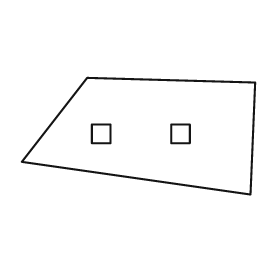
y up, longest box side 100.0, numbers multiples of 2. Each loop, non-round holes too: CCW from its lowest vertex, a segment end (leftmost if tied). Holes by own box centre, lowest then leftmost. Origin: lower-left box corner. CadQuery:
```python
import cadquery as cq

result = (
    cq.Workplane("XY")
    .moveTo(98.0, 0.0)
    .lineTo(100.0, 48.0)
    .lineTo(28.0, 50.0)
    .lineTo(0.0, 14.0)
    .close()
    .moveTo(30.0, 22.0)
    .lineTo(38.0, 22.0)
    .lineTo(38.0, 30.0)
    .lineTo(30.0, 30.0)
    .close()
    .moveTo(64.0, 22.0)
    .lineTo(72.0, 22.0)
    .lineTo(72.0, 30.0)
    .lineTo(64.0, 30.0)
    .close()
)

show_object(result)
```